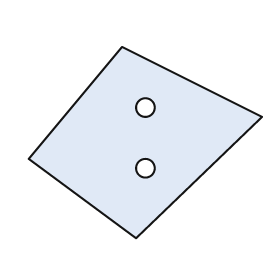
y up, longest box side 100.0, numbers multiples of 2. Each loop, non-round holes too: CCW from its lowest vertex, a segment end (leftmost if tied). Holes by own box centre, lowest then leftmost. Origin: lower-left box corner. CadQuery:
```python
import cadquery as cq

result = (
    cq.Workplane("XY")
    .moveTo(46.0, 0.0)
    .lineTo(100.0, 52.0)
    .lineTo(40.0, 82.0)
    .lineTo(0.0, 34.0)
    .close()
    .moveTo(50.0, 30.0)
    .circle(4.0)
    .moveTo(50.0, 56.0)
    .circle(4.0)
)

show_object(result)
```